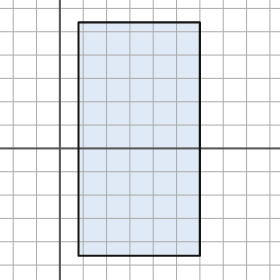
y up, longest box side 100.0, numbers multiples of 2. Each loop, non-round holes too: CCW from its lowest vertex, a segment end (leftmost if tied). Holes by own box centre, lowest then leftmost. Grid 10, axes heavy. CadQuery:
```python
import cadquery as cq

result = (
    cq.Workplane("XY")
    .moveTo(8.0, -46.0)
    .lineTo(60.0, -46.0)
    .lineTo(60.0, 54.0)
    .lineTo(8.0, 54.0)
    .close()
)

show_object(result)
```